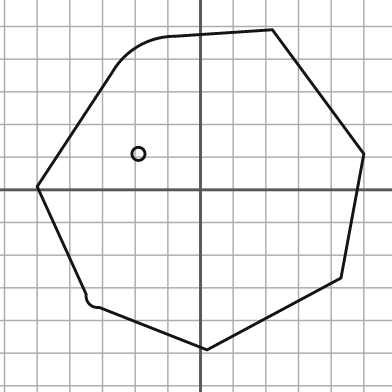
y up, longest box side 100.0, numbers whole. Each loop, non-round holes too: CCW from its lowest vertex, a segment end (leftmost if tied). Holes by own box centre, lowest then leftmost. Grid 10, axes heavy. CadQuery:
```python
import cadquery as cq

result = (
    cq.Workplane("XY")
    .moveTo(2.0, -49.0)
    .lineTo(43.0, -27.0)
    .lineTo(50.0, 11.0)
    .lineTo(22.0, 49.0)
    .lineTo(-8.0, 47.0)
    .threePointArc((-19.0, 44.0), (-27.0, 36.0))
    .lineTo(-50.0, 1.0)
    .lineTo(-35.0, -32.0)
    .threePointArc((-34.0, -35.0), (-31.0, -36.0))
    .close()
    .moveTo(-19.0, 11.0)
    .circle(2.0)
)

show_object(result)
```